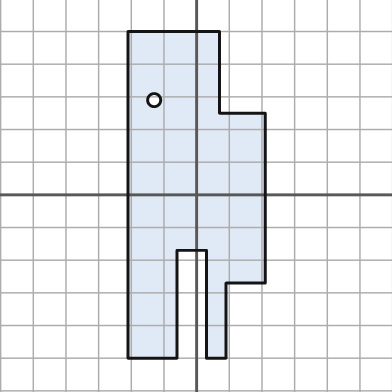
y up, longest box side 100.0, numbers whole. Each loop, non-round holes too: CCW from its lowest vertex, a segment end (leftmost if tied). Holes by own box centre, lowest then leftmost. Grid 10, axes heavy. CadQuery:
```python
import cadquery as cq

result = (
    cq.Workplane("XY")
    .moveTo(-21.0, -50.0)
    .lineTo(-6.0, -50.0)
    .lineTo(-6.0, -17.0)
    .lineTo(3.0, -17.0)
    .lineTo(3.0, -50.0)
    .lineTo(9.0, -50.0)
    .lineTo(9.0, -27.0)
    .lineTo(21.0, -27.0)
    .lineTo(21.0, 25.0)
    .lineTo(7.0, 25.0)
    .lineTo(7.0, 50.0)
    .lineTo(-21.0, 50.0)
    .close()
    .moveTo(-13.0, 29.0)
    .circle(2.0)
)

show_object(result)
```